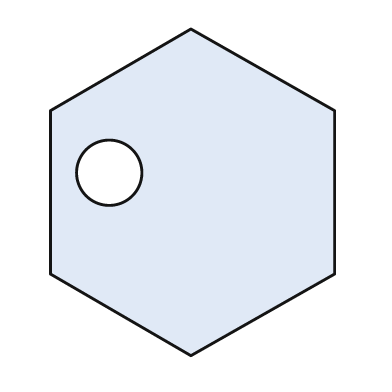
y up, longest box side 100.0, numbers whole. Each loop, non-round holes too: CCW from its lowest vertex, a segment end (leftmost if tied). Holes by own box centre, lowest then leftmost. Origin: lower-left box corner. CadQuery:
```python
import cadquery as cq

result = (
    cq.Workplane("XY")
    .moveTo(43.0, 0.0)
    .lineTo(87.0, 25.0)
    .lineTo(87.0, 75.0)
    .lineTo(43.0, 100.0)
    .lineTo(0.0, 75.0)
    .lineTo(0.0, 25.0)
    .close()
    .moveTo(18.0, 56.0)
    .circle(10.0)
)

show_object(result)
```